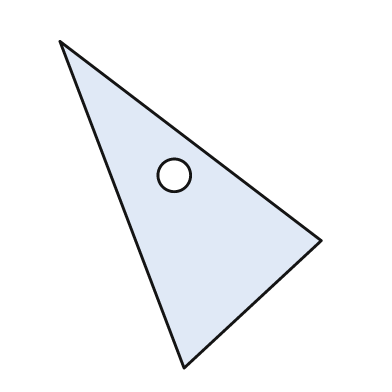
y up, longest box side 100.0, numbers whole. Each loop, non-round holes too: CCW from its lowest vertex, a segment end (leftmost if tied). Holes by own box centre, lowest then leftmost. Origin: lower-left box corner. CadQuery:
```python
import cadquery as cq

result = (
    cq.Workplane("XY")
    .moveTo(38.0, 0.0)
    .lineTo(80.0, 39.0)
    .lineTo(0.0, 100.0)
    .close()
    .moveTo(35.0, 59.0)
    .circle(5.0)
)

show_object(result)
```